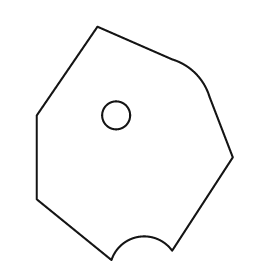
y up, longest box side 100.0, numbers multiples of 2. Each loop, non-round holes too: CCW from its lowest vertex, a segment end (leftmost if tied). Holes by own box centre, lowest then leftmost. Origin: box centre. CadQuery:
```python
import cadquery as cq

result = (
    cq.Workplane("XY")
    .moveTo(-10.0, -50.0)
    .threePointArc((2.0, -40.0), (16.0, -46.0))
    .lineTo(42.0, -6.0)
    .lineTo(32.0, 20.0)
    .threePointArc((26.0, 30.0), (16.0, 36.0))
    .lineTo(-16.0, 50.0)
    .lineTo(-42.0, 12.0)
    .lineTo(-42.0, -24.0)
    .close()
    .moveTo(-8.0, 12.0)
    .circle(6.0)
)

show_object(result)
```